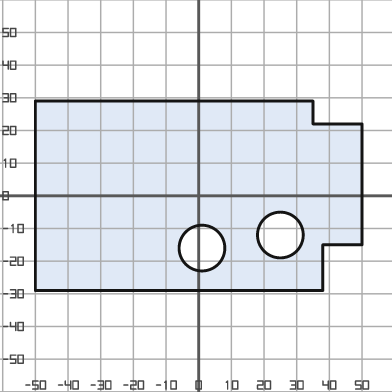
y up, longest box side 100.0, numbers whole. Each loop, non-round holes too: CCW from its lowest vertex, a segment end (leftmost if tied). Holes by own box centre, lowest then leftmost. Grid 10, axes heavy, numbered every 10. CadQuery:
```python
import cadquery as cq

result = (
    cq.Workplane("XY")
    .moveTo(-50.0, -29.0)
    .lineTo(38.0, -29.0)
    .lineTo(38.0, -15.0)
    .lineTo(50.0, -15.0)
    .lineTo(50.0, 22.0)
    .lineTo(35.0, 22.0)
    .lineTo(35.0, 29.0)
    .lineTo(-50.0, 29.0)
    .close()
    .moveTo(1.0, -16.0)
    .circle(7.0)
    .moveTo(25.0, -12.0)
    .circle(7.0)
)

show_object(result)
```